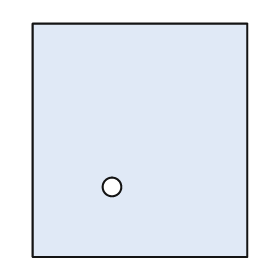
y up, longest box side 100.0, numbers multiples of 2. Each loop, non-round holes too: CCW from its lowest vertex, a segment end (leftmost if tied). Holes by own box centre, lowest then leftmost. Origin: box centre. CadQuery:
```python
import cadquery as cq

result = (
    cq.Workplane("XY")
    .moveTo(-46.0, -50.0)
    .lineTo(46.0, -50.0)
    .lineTo(46.0, 50.0)
    .lineTo(-46.0, 50.0)
    .close()
    .moveTo(-12.0, -20.0)
    .circle(4.0)
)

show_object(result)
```